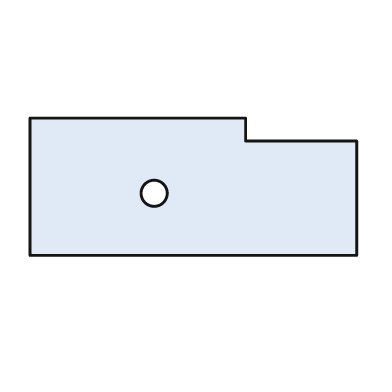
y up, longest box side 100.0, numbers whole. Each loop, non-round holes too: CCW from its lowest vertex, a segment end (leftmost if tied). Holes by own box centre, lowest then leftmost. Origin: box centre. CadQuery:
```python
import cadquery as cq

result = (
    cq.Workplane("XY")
    .moveTo(-50.0, -21.0)
    .lineTo(50.0, -21.0)
    .lineTo(50.0, 14.0)
    .lineTo(16.0, 14.0)
    .lineTo(16.0, 21.0)
    .lineTo(-50.0, 21.0)
    .close()
    .moveTo(-12.0, -2.0)
    .circle(4.0)
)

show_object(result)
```